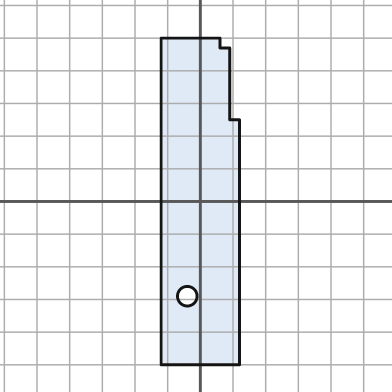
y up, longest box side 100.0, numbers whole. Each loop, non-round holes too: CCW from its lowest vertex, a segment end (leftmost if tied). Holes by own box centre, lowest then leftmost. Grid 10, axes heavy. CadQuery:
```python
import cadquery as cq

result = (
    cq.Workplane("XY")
    .moveTo(-12.0, -50.0)
    .lineTo(12.0, -50.0)
    .lineTo(12.0, 25.0)
    .lineTo(9.0, 25.0)
    .lineTo(9.0, 47.0)
    .lineTo(6.0, 47.0)
    .lineTo(6.0, 50.0)
    .lineTo(-12.0, 50.0)
    .close()
    .moveTo(-4.0, -29.0)
    .circle(3.0)
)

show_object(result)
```